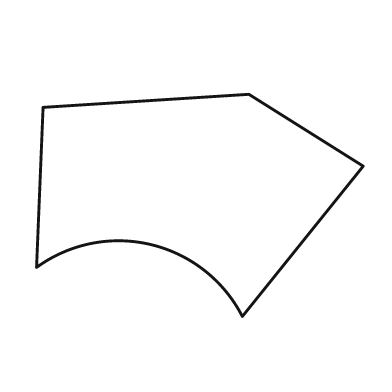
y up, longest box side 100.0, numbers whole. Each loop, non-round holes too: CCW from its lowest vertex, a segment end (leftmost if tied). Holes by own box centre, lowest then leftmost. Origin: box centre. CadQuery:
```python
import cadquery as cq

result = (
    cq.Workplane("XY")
    .moveTo(13.0, -34.0)
    .lineTo(50.0, 12.0)
    .lineTo(15.0, 34.0)
    .lineTo(-48.0, 30.0)
    .lineTo(-50.0, -19.0)
    .threePointArc((-15.0, -12.0), (13.0, -34.0))
    .close()
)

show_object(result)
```